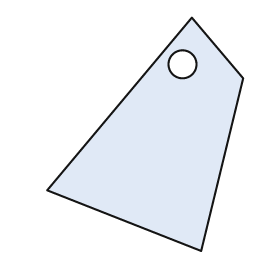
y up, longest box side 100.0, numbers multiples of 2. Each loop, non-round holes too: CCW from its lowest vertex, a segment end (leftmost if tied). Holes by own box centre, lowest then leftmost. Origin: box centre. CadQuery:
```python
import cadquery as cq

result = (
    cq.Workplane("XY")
    .moveTo(24.0, -50.0)
    .lineTo(42.0, 24.0)
    .lineTo(20.0, 50.0)
    .lineTo(-42.0, -24.0)
    .close()
    .moveTo(16.0, 30.0)
    .circle(6.0)
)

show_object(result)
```